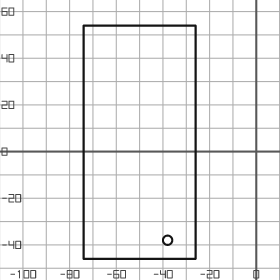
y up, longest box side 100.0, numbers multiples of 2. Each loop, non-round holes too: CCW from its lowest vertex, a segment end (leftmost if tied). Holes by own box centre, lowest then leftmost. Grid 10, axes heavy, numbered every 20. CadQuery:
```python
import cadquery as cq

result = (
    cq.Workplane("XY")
    .moveTo(-74.0, -46.0)
    .lineTo(-26.0, -46.0)
    .lineTo(-26.0, 54.0)
    .lineTo(-74.0, 54.0)
    .close()
    .moveTo(-38.0, -38.0)
    .circle(2.0)
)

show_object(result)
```